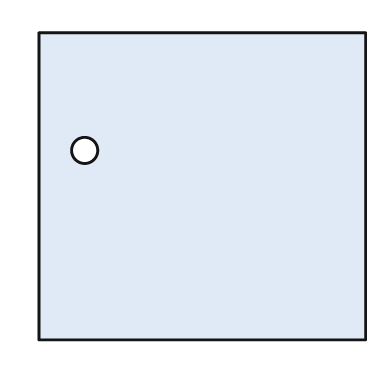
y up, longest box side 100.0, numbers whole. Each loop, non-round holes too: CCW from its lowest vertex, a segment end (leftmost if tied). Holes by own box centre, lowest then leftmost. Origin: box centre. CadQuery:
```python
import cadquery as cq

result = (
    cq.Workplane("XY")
    .moveTo(-50.0, -47.0)
    .lineTo(50.0, -47.0)
    .lineTo(50.0, 47.0)
    .lineTo(-50.0, 47.0)
    .close()
    .moveTo(-36.0, 11.0)
    .circle(4.0)
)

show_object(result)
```